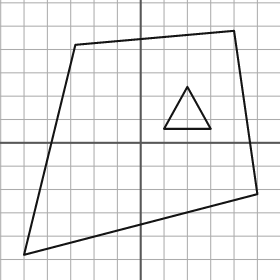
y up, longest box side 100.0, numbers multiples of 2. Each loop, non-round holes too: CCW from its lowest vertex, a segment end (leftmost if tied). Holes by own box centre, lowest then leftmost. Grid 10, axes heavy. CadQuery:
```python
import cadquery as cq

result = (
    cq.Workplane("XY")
    .moveTo(-50.0, -48.0)
    .lineTo(50.0, -22.0)
    .lineTo(40.0, 48.0)
    .lineTo(-28.0, 42.0)
    .close()
    .moveTo(10.0, 6.0)
    .lineTo(30.0, 6.0)
    .lineTo(20.0, 24.0)
    .close()
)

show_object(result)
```